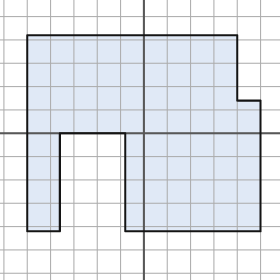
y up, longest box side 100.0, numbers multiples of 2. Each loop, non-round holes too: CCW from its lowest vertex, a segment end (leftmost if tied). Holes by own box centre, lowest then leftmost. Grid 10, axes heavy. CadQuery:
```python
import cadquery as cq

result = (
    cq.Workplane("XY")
    .moveTo(-50.0, -42.0)
    .lineTo(-36.0, -42.0)
    .lineTo(-36.0, 0.0)
    .lineTo(-8.0, 0.0)
    .lineTo(-8.0, -42.0)
    .lineTo(50.0, -42.0)
    .lineTo(50.0, 14.0)
    .lineTo(40.0, 14.0)
    .lineTo(40.0, 42.0)
    .lineTo(-50.0, 42.0)
    .close()
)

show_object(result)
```